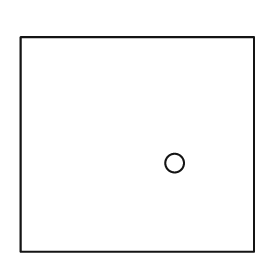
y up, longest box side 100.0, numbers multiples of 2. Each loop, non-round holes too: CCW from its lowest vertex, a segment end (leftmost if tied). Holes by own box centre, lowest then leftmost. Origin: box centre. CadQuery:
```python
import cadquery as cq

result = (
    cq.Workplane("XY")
    .moveTo(-50.0, -46.0)
    .lineTo(50.0, -46.0)
    .lineTo(50.0, 46.0)
    .lineTo(-50.0, 46.0)
    .close()
    .moveTo(16.0, -8.0)
    .circle(4.0)
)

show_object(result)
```